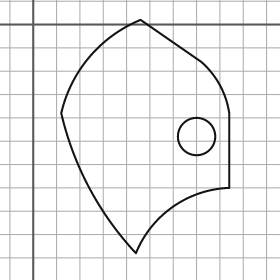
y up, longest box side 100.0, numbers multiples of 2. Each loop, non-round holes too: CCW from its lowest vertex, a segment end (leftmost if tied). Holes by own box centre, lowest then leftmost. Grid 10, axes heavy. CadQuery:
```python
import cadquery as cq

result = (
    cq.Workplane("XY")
    .moveTo(44.0, -98.0)
    .threePointArc((60.0, -78.0), (84.0, -70.0))
    .lineTo(84.0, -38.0)
    .threePointArc((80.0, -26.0), (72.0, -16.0))
    .lineTo(46.0, 2.0)
    .threePointArc((24.0, -14.0), (12.0, -38.0))
    .threePointArc((24.0, -70.0), (44.0, -98.0))
    .close()
    .moveTo(70.0, -48.0)
    .circle(8.0)
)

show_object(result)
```